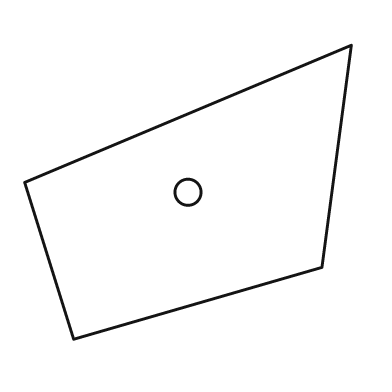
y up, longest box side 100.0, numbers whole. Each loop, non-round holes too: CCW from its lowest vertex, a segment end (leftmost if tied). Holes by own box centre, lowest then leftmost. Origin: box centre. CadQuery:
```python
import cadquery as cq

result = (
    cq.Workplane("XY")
    .moveTo(-35.0, -45.0)
    .lineTo(41.0, -23.0)
    .lineTo(50.0, 45.0)
    .lineTo(-50.0, 3.0)
    .close()
    .moveTo(0.0, 0.0)
    .circle(4.0)
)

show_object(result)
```